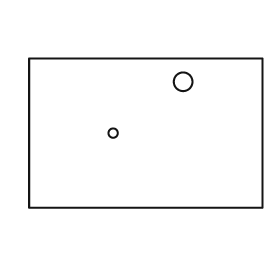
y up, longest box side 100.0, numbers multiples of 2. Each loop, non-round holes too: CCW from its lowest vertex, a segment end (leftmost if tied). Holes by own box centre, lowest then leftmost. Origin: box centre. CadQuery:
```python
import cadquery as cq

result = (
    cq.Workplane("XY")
    .moveTo(-50.0, -32.0)
    .lineTo(50.0, -32.0)
    .lineTo(50.0, 32.0)
    .lineTo(-50.0, 32.0)
    .close()
    .moveTo(-14.0, 0.0)
    .circle(2.0)
    .moveTo(16.0, 22.0)
    .circle(4.0)
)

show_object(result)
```